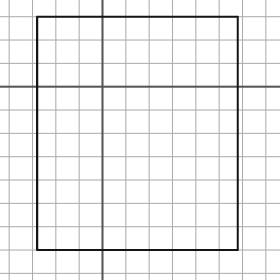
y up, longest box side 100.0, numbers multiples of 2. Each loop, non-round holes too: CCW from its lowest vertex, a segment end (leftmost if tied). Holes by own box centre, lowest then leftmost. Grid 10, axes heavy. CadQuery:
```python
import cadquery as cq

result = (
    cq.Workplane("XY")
    .moveTo(-28.0, -70.0)
    .lineTo(58.0, -70.0)
    .lineTo(58.0, 30.0)
    .lineTo(-28.0, 30.0)
    .close()
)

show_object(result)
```